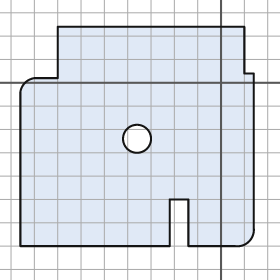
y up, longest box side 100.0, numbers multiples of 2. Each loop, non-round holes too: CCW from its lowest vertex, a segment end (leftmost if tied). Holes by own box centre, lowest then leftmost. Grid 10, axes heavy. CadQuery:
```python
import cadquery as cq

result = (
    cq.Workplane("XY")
    .moveTo(-86.0, -70.0)
    .lineTo(-22.0, -70.0)
    .lineTo(-22.0, -50.0)
    .lineTo(-14.0, -50.0)
    .lineTo(-14.0, -70.0)
    .lineTo(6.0, -70.0)
    .threePointArc((12.0, -68.0), (14.0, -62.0))
    .lineTo(14.0, 4.0)
    .lineTo(10.0, 4.0)
    .lineTo(10.0, 24.0)
    .lineTo(-70.0, 24.0)
    .lineTo(-70.0, 2.0)
    .lineTo(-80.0, 2.0)
    .threePointArc((-84.0, 0.0), (-86.0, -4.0))
    .close()
    .moveTo(-36.0, -24.0)
    .circle(6.0)
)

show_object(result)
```